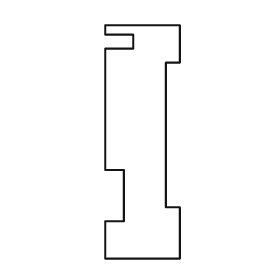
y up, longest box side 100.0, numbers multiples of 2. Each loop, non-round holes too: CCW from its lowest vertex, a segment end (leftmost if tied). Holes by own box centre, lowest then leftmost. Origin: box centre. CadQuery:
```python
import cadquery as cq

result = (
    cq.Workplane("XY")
    .moveTo(-16.0, -50.0)
    .lineTo(16.0, -50.0)
    .lineTo(16.0, -28.0)
    .lineTo(10.0, -28.0)
    .lineTo(10.0, 34.0)
    .lineTo(16.0, 34.0)
    .lineTo(16.0, 50.0)
    .lineTo(-16.0, 50.0)
    .lineTo(-16.0, 46.0)
    .lineTo(-4.0, 46.0)
    .lineTo(-4.0, 40.0)
    .lineTo(-16.0, 40.0)
    .lineTo(-16.0, -12.0)
    .lineTo(-8.0, -12.0)
    .lineTo(-8.0, -34.0)
    .lineTo(-16.0, -34.0)
    .close()
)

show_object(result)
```